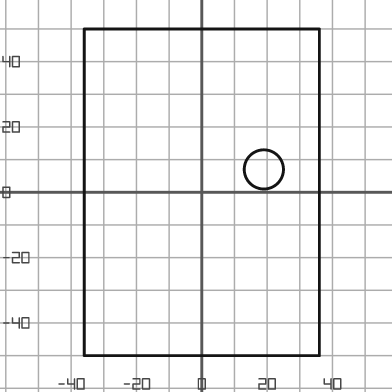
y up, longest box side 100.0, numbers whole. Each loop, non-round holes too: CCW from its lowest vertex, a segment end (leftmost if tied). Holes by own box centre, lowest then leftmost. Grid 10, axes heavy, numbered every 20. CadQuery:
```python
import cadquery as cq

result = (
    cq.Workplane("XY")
    .moveTo(-36.0, -50.0)
    .lineTo(36.0, -50.0)
    .lineTo(36.0, 50.0)
    .lineTo(-36.0, 50.0)
    .close()
    .moveTo(19.0, 7.0)
    .circle(6.0)
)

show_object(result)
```